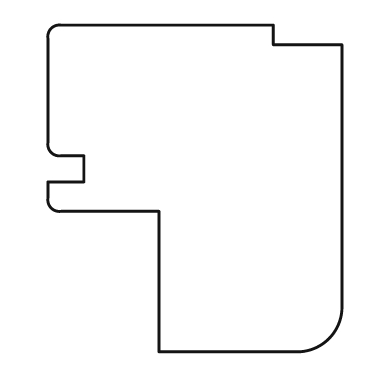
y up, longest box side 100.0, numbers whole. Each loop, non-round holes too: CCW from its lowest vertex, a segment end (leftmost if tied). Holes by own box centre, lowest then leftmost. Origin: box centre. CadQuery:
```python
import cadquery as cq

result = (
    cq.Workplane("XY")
    .moveTo(-11.0, -50.0)
    .lineTo(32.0, -50.0)
    .threePointArc((41.0, -46.0), (45.0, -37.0))
    .lineTo(45.0, 44.0)
    .lineTo(24.0, 44.0)
    .lineTo(24.0, 50.0)
    .lineTo(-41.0, 50.0)
    .threePointArc((-44.0, 49.0), (-45.0, 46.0))
    .lineTo(-45.0, 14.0)
    .threePointArc((-44.0, 11.0), (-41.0, 10.0))
    .lineTo(-34.0, 10.0)
    .lineTo(-34.0, 2.0)
    .lineTo(-45.0, 2.0)
    .lineTo(-45.0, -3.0)
    .threePointArc((-44.0, -6.0), (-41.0, -7.0))
    .lineTo(-11.0, -7.0)
    .close()
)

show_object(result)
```